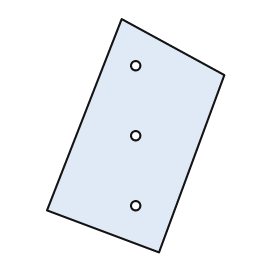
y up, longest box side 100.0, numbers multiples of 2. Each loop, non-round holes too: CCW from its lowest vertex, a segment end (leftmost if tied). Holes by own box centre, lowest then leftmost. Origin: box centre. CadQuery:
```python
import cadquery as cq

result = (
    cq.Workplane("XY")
    .moveTo(10.0, -50.0)
    .lineTo(38.0, 26.0)
    .lineTo(-6.0, 50.0)
    .lineTo(-38.0, -32.0)
    .close()
    .moveTo(0.0, -30.0)
    .circle(2.0)
    .moveTo(0.0, 0.0)
    .circle(2.0)
    .moveTo(0.0, 30.0)
    .circle(2.0)
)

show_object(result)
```